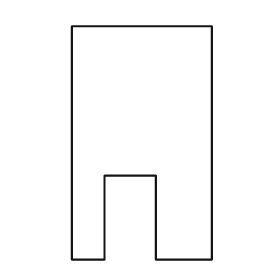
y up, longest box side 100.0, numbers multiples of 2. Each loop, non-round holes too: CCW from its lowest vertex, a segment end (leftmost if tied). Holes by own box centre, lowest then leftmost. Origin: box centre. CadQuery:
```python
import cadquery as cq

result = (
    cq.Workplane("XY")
    .moveTo(-30.0, -50.0)
    .lineTo(-16.0, -50.0)
    .lineTo(-16.0, -14.0)
    .lineTo(6.0, -14.0)
    .lineTo(6.0, -50.0)
    .lineTo(30.0, -50.0)
    .lineTo(30.0, 50.0)
    .lineTo(-30.0, 50.0)
    .close()
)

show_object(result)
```